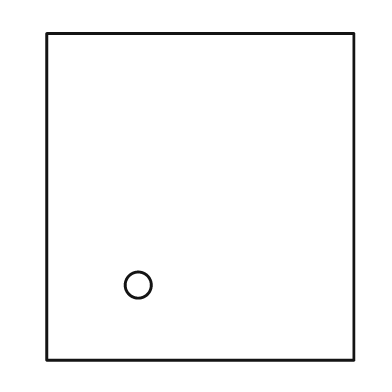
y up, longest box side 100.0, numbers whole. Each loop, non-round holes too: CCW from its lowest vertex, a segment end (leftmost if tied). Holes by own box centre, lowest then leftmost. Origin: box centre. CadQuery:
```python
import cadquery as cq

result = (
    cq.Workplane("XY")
    .moveTo(-47.0, -50.0)
    .lineTo(47.0, -50.0)
    .lineTo(47.0, 50.0)
    .lineTo(-47.0, 50.0)
    .close()
    .moveTo(-19.0, -27.0)
    .circle(4.0)
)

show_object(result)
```